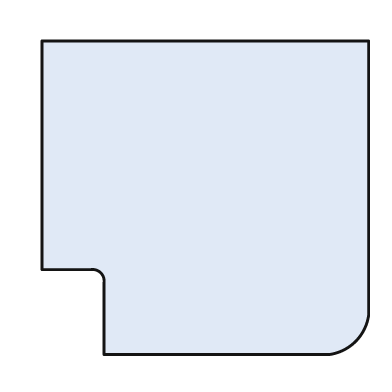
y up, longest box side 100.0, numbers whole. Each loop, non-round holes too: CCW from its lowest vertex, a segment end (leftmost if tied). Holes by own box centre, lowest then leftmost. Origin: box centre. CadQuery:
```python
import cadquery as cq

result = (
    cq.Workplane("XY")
    .moveTo(-31.0, -48.0)
    .lineTo(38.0, -48.0)
    .threePointArc((46.0, -44.0), (50.0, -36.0))
    .lineTo(50.0, 48.0)
    .lineTo(-50.0, 48.0)
    .lineTo(-50.0, -22.0)
    .lineTo(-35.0, -22.0)
    .threePointArc((-32.0, -23.0), (-31.0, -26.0))
    .close()
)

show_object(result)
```